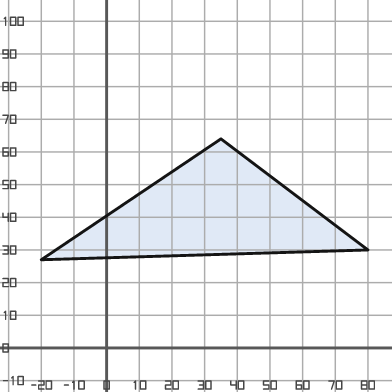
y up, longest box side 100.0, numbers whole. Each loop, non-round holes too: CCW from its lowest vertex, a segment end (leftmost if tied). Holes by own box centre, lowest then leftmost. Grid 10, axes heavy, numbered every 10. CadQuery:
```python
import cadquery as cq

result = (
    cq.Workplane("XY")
    .moveTo(-20.0, 27.0)
    .lineTo(80.0, 30.0)
    .lineTo(35.0, 64.0)
    .close()
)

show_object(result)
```